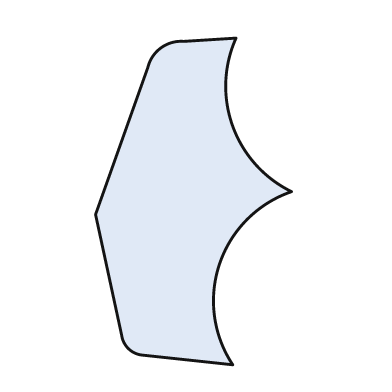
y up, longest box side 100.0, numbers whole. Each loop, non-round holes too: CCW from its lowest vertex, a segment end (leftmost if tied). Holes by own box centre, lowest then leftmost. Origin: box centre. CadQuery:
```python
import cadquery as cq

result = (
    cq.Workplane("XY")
    .moveTo(12.0, -50.0)
    .threePointArc((8.0, -19.0), (30.0, 3.0))
    .threePointArc((12.0, 23.0), (13.0, 50.0))
    .lineTo(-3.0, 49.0)
    .threePointArc((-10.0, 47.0), (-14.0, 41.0))
    .lineTo(-30.0, -4.0)
    .lineTo(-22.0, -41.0)
    .threePointArc((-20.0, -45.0), (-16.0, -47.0))
    .close()
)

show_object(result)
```